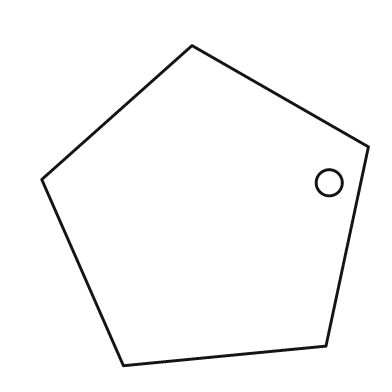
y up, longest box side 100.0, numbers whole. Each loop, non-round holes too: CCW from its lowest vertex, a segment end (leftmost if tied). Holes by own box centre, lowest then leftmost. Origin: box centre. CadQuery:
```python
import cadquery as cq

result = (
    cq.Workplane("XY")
    .moveTo(-25.0, -49.0)
    .lineTo(37.0, -43.0)
    .lineTo(50.0, 18.0)
    .lineTo(-4.0, 49.0)
    .lineTo(-50.0, 8.0)
    .close()
    .moveTo(38.0, 7.0)
    .circle(4.0)
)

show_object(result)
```